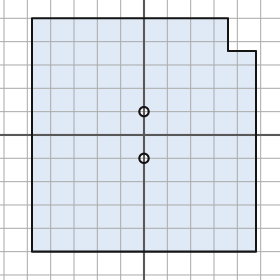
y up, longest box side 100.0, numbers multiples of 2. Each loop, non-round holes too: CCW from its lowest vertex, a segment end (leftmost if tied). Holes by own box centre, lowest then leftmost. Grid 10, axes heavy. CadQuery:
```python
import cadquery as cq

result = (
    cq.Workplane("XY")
    .moveTo(-48.0, -50.0)
    .lineTo(48.0, -50.0)
    .lineTo(48.0, 36.0)
    .lineTo(36.0, 36.0)
    .lineTo(36.0, 50.0)
    .lineTo(-48.0, 50.0)
    .close()
    .moveTo(0.0, -10.0)
    .circle(2.0)
    .moveTo(0.0, 10.0)
    .circle(2.0)
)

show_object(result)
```